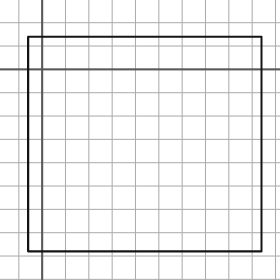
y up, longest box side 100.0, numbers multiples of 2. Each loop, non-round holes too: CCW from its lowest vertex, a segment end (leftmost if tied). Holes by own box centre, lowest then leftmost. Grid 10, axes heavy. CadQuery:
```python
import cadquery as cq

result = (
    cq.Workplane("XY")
    .moveTo(-6.0, -78.0)
    .lineTo(94.0, -78.0)
    .lineTo(94.0, 14.0)
    .lineTo(-6.0, 14.0)
    .close()
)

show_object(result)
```